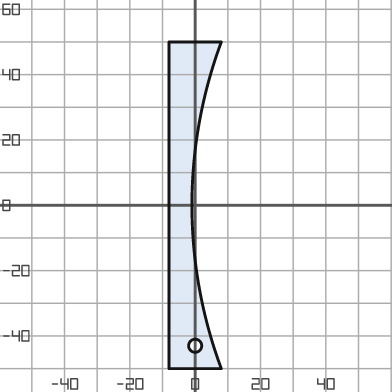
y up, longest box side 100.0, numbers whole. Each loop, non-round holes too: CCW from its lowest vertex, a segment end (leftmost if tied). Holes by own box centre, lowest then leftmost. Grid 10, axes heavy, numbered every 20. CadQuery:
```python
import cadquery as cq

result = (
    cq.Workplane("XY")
    .moveTo(-8.0, -50.0)
    .lineTo(8.0, -50.0)
    .threePointArc((-1.0, 0.0), (8.0, 50.0))
    .lineTo(-8.0, 50.0)
    .close()
    .moveTo(0.0, -43.0)
    .circle(2.0)
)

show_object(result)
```